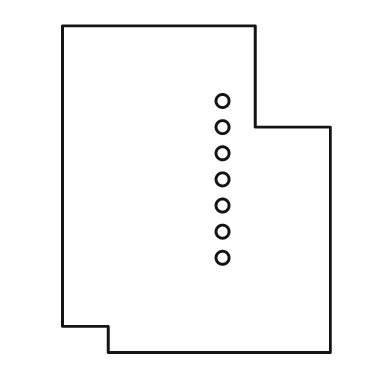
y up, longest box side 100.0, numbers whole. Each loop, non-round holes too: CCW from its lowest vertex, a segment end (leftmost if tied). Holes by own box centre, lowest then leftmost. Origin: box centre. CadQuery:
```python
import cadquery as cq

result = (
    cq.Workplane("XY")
    .moveTo(-27.0, -50.0)
    .lineTo(41.0, -50.0)
    .lineTo(41.0, 19.0)
    .lineTo(18.0, 19.0)
    .lineTo(18.0, 50.0)
    .lineTo(-41.0, 50.0)
    .lineTo(-41.0, -42.0)
    .lineTo(-27.0, -42.0)
    .close()
    .moveTo(8.0, -21.0)
    .circle(2.0)
    .moveTo(8.0, -13.0)
    .circle(2.0)
    .moveTo(8.0, -5.0)
    .circle(2.0)
    .moveTo(8.0, 3.0)
    .circle(2.0)
    .moveTo(8.0, 11.0)
    .circle(2.0)
    .moveTo(8.0, 19.0)
    .circle(2.0)
    .moveTo(8.0, 27.0)
    .circle(2.0)
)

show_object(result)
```